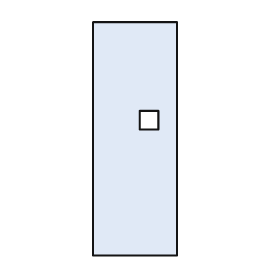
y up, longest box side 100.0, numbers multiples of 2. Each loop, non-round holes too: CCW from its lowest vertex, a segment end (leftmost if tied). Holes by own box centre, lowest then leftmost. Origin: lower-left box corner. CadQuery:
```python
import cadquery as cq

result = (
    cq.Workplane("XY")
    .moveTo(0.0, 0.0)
    .lineTo(36.0, 0.0)
    .lineTo(36.0, 100.0)
    .lineTo(0.0, 100.0)
    .close()
    .moveTo(20.0, 54.0)
    .lineTo(28.0, 54.0)
    .lineTo(28.0, 62.0)
    .lineTo(20.0, 62.0)
    .close()
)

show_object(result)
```